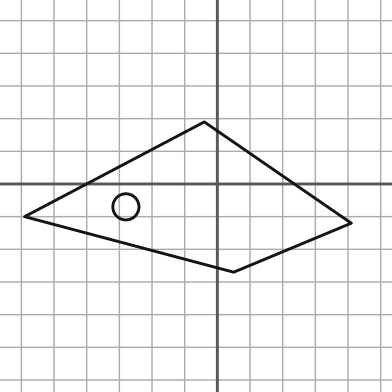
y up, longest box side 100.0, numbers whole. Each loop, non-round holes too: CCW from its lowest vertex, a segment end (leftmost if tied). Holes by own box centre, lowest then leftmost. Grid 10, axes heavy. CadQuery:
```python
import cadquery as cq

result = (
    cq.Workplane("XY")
    .moveTo(5.0, -27.0)
    .lineTo(41.0, -12.0)
    .lineTo(-4.0, 19.0)
    .lineTo(-59.0, -10.0)
    .close()
    .moveTo(-28.0, -7.0)
    .circle(4.0)
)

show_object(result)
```